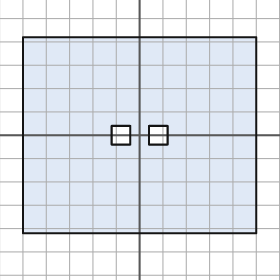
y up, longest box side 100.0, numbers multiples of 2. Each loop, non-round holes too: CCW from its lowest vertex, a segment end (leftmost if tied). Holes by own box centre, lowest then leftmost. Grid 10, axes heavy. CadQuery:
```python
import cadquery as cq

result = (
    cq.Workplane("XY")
    .moveTo(-50.0, -42.0)
    .lineTo(50.0, -42.0)
    .lineTo(50.0, 42.0)
    .lineTo(-50.0, 42.0)
    .close()
    .moveTo(-12.0, -4.0)
    .lineTo(-4.0, -4.0)
    .lineTo(-4.0, 4.0)
    .lineTo(-12.0, 4.0)
    .close()
    .moveTo(4.0, -4.0)
    .lineTo(12.0, -4.0)
    .lineTo(12.0, 4.0)
    .lineTo(4.0, 4.0)
    .close()
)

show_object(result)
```